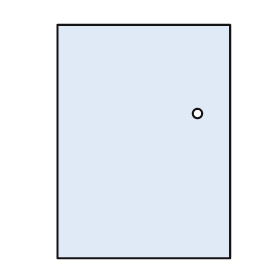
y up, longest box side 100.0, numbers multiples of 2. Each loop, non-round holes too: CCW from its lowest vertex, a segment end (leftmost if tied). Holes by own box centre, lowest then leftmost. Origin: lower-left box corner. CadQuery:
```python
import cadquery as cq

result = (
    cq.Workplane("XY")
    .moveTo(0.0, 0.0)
    .lineTo(74.0, 0.0)
    .lineTo(74.0, 100.0)
    .lineTo(0.0, 100.0)
    .close()
    .moveTo(60.0, 62.0)
    .circle(2.0)
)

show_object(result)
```